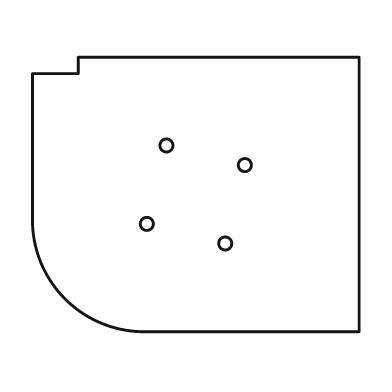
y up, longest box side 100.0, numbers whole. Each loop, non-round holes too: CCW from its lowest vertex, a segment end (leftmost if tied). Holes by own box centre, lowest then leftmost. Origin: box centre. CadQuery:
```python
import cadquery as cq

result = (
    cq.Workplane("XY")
    .moveTo(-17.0, -42.0)
    .lineTo(50.0, -42.0)
    .lineTo(50.0, 42.0)
    .lineTo(-36.0, 42.0)
    .lineTo(-36.0, 37.0)
    .lineTo(-50.0, 37.0)
    .lineTo(-50.0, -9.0)
    .threePointArc((-40.0, -32.0), (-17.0, -42.0))
    .close()
    .moveTo(9.0, -15.0)
    .circle(2.0)
    .moveTo(-15.0, -9.0)
    .circle(2.0)
    .moveTo(15.0, 9.0)
    .circle(2.0)
    .moveTo(-9.0, 15.0)
    .circle(2.0)
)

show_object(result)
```